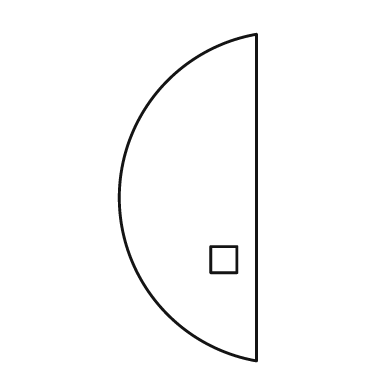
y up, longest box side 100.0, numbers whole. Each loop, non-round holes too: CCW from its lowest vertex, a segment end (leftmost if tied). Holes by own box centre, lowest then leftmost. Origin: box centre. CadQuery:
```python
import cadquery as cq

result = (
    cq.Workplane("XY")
    .moveTo(21.0, -50.0)
    .lineTo(21.0, 50.0)
    .threePointArc((-21.0, 0.0), (21.0, -50.0))
    .close()
    .moveTo(7.0, -23.0)
    .lineTo(15.0, -23.0)
    .lineTo(15.0, -15.0)
    .lineTo(7.0, -15.0)
    .close()
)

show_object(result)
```